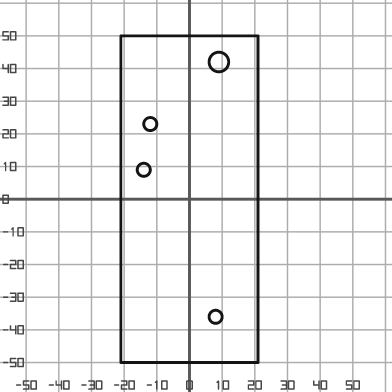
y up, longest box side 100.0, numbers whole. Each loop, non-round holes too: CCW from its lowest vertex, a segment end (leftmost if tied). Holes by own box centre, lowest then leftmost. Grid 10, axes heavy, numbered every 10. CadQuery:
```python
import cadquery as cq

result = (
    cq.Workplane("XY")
    .moveTo(-21.0, -50.0)
    .lineTo(21.0, -50.0)
    .lineTo(21.0, 50.0)
    .lineTo(-21.0, 50.0)
    .close()
    .moveTo(8.0, -36.0)
    .circle(2.0)
    .moveTo(-14.0, 9.0)
    .circle(2.0)
    .moveTo(-12.0, 23.0)
    .circle(2.0)
    .moveTo(9.0, 42.0)
    .circle(3.0)
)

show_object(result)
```